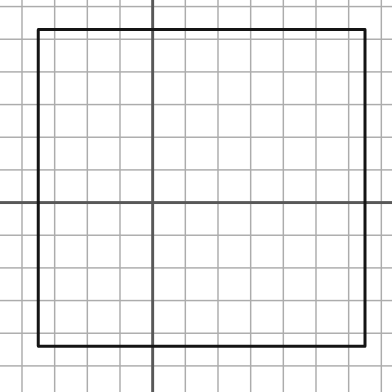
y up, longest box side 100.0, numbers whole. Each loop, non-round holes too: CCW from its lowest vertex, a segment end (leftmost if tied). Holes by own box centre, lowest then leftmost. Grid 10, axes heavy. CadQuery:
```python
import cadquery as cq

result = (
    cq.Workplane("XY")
    .moveTo(-35.0, -44.0)
    .lineTo(65.0, -44.0)
    .lineTo(65.0, 53.0)
    .lineTo(-35.0, 53.0)
    .close()
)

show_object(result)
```